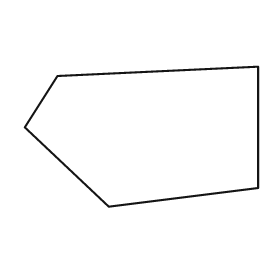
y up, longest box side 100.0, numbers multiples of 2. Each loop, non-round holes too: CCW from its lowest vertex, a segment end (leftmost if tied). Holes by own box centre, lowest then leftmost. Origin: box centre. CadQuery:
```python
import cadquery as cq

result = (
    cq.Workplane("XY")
    .moveTo(-14.0, -30.0)
    .lineTo(50.0, -22.0)
    .lineTo(50.0, 30.0)
    .lineTo(-36.0, 26.0)
    .lineTo(-50.0, 4.0)
    .close()
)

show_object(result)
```